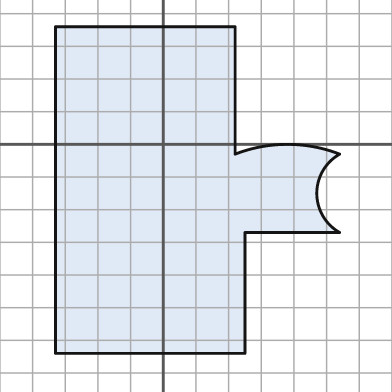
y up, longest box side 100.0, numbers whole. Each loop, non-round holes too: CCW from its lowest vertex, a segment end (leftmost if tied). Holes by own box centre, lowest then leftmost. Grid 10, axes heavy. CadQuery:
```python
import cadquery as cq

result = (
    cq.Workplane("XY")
    .moveTo(-33.0, -64.0)
    .lineTo(25.0, -64.0)
    .lineTo(25.0, -27.0)
    .lineTo(54.0, -27.0)
    .threePointArc((47.0, -15.0), (54.0, -3.0))
    .threePointArc((38.0, 0.0), (22.0, -3.0))
    .lineTo(22.0, 36.0)
    .lineTo(-33.0, 36.0)
    .close()
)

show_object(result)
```